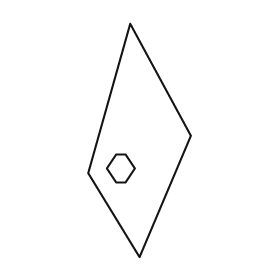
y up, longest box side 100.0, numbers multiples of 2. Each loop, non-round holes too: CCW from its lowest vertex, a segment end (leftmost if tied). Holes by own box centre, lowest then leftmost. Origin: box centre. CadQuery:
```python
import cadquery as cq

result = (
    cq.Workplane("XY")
    .moveTo(0.0, -50.0)
    .lineTo(22.0, 2.0)
    .lineTo(-4.0, 50.0)
    .lineTo(-22.0, -14.0)
    .close()
    .moveTo(-10.0, -18.0)
    .lineTo(-6.0, -18.0)
    .lineTo(-2.0, -12.0)
    .lineTo(-6.0, -6.0)
    .lineTo(-10.0, -6.0)
    .lineTo(-14.0, -12.0)
    .close()
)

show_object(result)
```